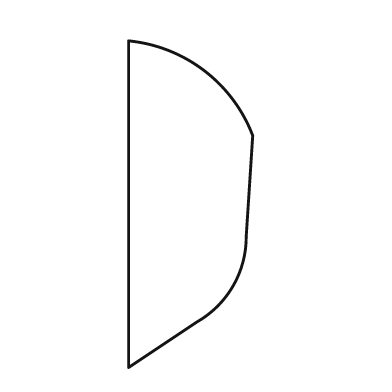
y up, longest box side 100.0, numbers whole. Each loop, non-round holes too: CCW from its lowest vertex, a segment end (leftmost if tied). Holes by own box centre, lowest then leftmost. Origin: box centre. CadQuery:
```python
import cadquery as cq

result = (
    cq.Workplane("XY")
    .moveTo(-19.0, -50.0)
    .lineTo(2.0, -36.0)
    .threePointArc((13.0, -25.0), (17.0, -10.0))
    .lineTo(19.0, 21.0)
    .threePointArc((4.0, 41.0), (-19.0, 50.0))
    .close()
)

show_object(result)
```